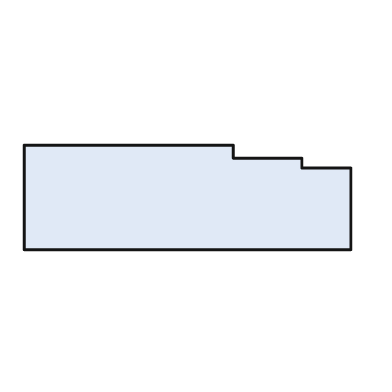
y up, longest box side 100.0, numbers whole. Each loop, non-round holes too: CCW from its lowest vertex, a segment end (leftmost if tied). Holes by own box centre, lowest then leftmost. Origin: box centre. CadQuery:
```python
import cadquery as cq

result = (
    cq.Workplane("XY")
    .moveTo(-50.0, -16.0)
    .lineTo(50.0, -16.0)
    .lineTo(50.0, 9.0)
    .lineTo(35.0, 9.0)
    .lineTo(35.0, 12.0)
    .lineTo(14.0, 12.0)
    .lineTo(14.0, 16.0)
    .lineTo(-50.0, 16.0)
    .close()
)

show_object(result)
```